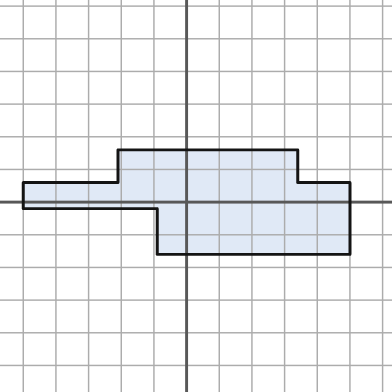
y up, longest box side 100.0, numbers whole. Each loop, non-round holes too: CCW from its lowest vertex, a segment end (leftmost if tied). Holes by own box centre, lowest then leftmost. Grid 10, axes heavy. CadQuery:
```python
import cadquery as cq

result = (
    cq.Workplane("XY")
    .moveTo(-9.0, -16.0)
    .lineTo(50.0, -16.0)
    .lineTo(50.0, 6.0)
    .lineTo(34.0, 6.0)
    .lineTo(34.0, 16.0)
    .lineTo(-21.0, 16.0)
    .lineTo(-21.0, 6.0)
    .lineTo(-50.0, 6.0)
    .lineTo(-50.0, -2.0)
    .lineTo(-9.0, -2.0)
    .close()
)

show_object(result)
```